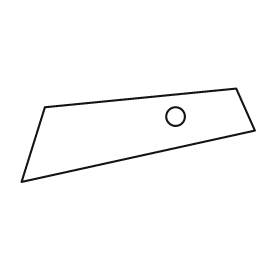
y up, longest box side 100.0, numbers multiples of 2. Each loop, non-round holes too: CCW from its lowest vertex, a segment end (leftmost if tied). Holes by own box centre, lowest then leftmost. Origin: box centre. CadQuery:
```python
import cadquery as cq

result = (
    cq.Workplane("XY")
    .moveTo(-50.0, -20.0)
    .lineTo(50.0, 2.0)
    .lineTo(42.0, 20.0)
    .lineTo(-40.0, 12.0)
    .close()
    .moveTo(16.0, 8.0)
    .circle(4.0)
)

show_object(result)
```